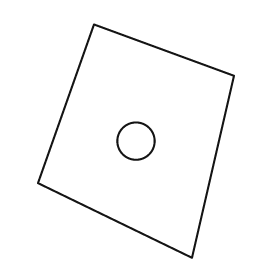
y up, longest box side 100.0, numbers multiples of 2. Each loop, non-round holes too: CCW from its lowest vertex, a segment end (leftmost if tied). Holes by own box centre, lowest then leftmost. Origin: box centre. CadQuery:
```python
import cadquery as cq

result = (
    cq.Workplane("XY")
    .moveTo(24.0, -50.0)
    .lineTo(42.0, 28.0)
    .lineTo(-18.0, 50.0)
    .lineTo(-42.0, -18.0)
    .close()
    .moveTo(0.0, 0.0)
    .circle(8.0)
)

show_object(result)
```